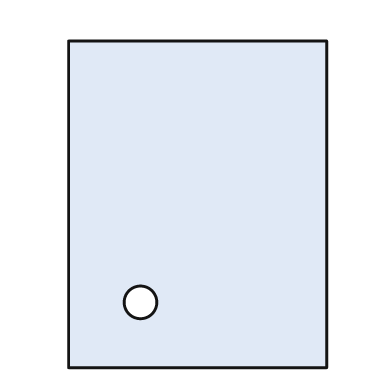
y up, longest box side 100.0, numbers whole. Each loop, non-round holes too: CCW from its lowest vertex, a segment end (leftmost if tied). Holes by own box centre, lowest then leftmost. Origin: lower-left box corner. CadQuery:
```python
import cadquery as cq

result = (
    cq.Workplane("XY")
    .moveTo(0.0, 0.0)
    .lineTo(79.0, 0.0)
    .lineTo(79.0, 100.0)
    .lineTo(0.0, 100.0)
    .close()
    .moveTo(22.0, 20.0)
    .circle(5.0)
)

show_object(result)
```